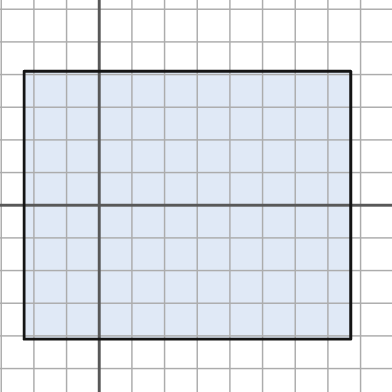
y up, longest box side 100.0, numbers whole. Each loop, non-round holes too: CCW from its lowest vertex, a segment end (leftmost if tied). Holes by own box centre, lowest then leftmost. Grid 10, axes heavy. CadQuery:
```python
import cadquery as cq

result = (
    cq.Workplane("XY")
    .moveTo(-23.0, -41.0)
    .lineTo(77.0, -41.0)
    .lineTo(77.0, 41.0)
    .lineTo(-23.0, 41.0)
    .close()
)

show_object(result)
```